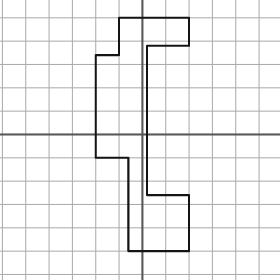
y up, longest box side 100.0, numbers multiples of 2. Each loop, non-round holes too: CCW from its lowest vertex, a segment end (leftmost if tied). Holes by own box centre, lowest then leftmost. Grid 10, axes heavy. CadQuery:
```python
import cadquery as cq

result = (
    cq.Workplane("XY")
    .moveTo(-6.0, -50.0)
    .lineTo(20.0, -50.0)
    .lineTo(20.0, -26.0)
    .lineTo(2.0, -26.0)
    .lineTo(2.0, 38.0)
    .lineTo(20.0, 38.0)
    .lineTo(20.0, 50.0)
    .lineTo(-10.0, 50.0)
    .lineTo(-10.0, 34.0)
    .lineTo(-20.0, 34.0)
    .lineTo(-20.0, -10.0)
    .lineTo(-6.0, -10.0)
    .close()
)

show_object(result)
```